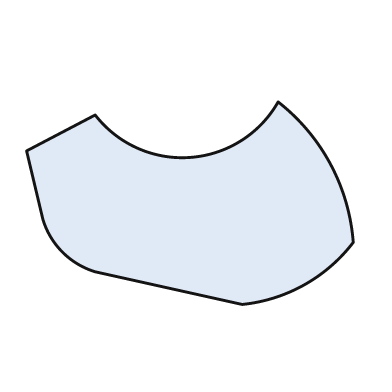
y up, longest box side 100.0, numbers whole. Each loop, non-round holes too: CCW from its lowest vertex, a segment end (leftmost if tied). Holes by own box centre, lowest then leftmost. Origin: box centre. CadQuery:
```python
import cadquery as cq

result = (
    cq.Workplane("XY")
    .moveTo(16.0, -31.0)
    .threePointArc((35.0, -25.0), (50.0, -12.0))
    .threePointArc((43.0, 12.0), (27.0, 31.0))
    .threePointArc((0.0, 14.0), (-29.0, 27.0))
    .lineTo(-50.0, 16.0)
    .lineTo(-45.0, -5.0)
    .threePointArc((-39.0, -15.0), (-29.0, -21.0))
    .close()
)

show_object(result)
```